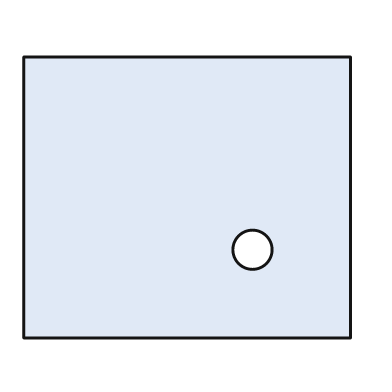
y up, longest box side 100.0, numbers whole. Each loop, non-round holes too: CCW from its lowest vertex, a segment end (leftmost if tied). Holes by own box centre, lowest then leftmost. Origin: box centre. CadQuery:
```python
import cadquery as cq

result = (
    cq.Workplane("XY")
    .moveTo(-50.0, -43.0)
    .lineTo(50.0, -43.0)
    .lineTo(50.0, 43.0)
    .lineTo(-50.0, 43.0)
    .close()
    .moveTo(20.0, -16.0)
    .circle(6.0)
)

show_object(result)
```